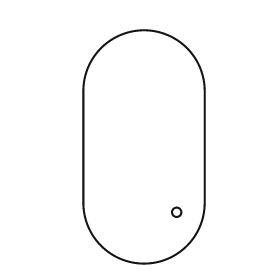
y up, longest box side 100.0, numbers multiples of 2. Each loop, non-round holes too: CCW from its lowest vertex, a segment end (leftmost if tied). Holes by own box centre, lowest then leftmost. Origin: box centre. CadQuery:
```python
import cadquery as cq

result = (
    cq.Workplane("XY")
    .moveTo(-26.0, -24.0)
    .threePointArc((0.0, -50.0), (26.0, -24.0))
    .lineTo(26.0, 24.0)
    .threePointArc((0.0, 50.0), (-26.0, 24.0))
    .close()
    .moveTo(14.0, -28.0)
    .circle(2.0)
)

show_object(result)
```